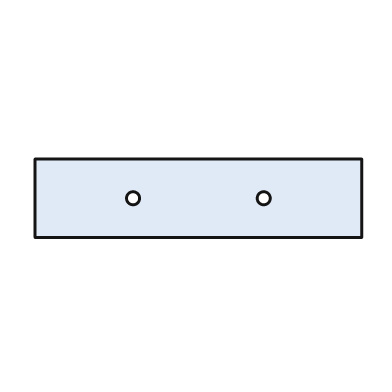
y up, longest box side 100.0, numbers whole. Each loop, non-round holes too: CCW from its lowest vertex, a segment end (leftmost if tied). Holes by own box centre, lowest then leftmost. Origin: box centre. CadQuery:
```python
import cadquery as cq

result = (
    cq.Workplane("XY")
    .moveTo(-50.0, -12.0)
    .lineTo(50.0, -12.0)
    .lineTo(50.0, 12.0)
    .lineTo(-50.0, 12.0)
    .close()
    .moveTo(-20.0, 0.0)
    .circle(2.0)
    .moveTo(20.0, 0.0)
    .circle(2.0)
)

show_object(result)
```